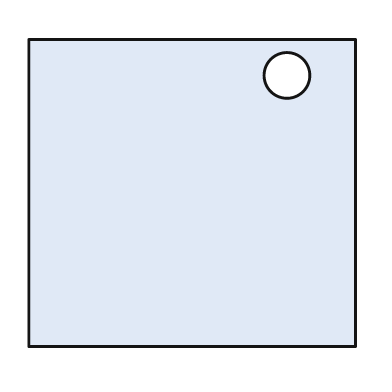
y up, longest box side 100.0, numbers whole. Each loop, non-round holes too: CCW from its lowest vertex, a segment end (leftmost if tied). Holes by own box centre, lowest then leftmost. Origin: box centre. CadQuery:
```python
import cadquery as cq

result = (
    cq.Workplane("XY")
    .moveTo(-50.0, -47.0)
    .lineTo(50.0, -47.0)
    .lineTo(50.0, 47.0)
    .lineTo(-50.0, 47.0)
    .close()
    .moveTo(29.0, 36.0)
    .circle(7.0)
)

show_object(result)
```